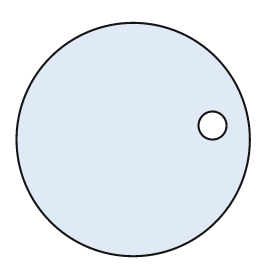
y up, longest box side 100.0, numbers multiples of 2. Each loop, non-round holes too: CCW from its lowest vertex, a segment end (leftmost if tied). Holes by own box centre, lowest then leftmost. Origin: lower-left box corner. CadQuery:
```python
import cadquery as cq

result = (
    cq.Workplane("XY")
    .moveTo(50.0, 50.0)
    .circle(50.0)
    .moveTo(84.0, 56.0)
    .circle(6.0)
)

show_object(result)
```